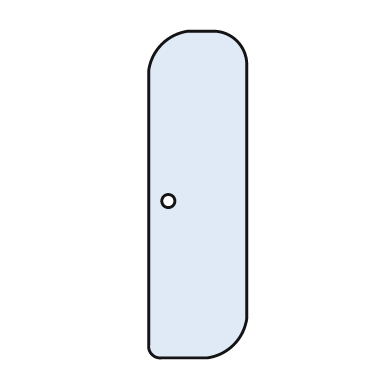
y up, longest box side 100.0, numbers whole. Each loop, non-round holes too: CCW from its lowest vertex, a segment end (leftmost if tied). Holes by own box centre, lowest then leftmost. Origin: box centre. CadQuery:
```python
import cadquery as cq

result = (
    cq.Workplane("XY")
    .moveTo(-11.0, -50.0)
    .lineTo(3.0, -50.0)
    .threePointArc((11.0, -46.0), (15.0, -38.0))
    .lineTo(15.0, 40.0)
    .threePointArc((12.0, 47.0), (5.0, 50.0))
    .lineTo(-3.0, 50.0)
    .threePointArc((-11.0, 46.0), (-15.0, 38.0))
    .lineTo(-15.0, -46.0)
    .threePointArc((-14.0, -49.0), (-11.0, -50.0))
    .close()
    .moveTo(-9.0, -2.0)
    .circle(2.0)
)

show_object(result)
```